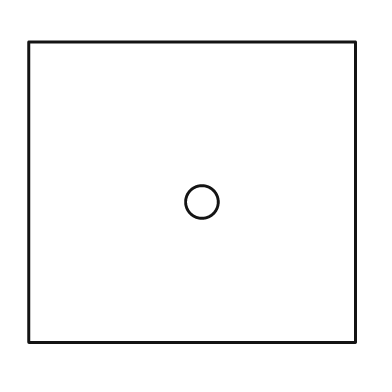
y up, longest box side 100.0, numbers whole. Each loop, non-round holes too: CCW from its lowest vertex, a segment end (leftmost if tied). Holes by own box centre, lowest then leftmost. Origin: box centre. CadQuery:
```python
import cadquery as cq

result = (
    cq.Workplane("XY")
    .moveTo(-50.0, -46.0)
    .lineTo(50.0, -46.0)
    .lineTo(50.0, 46.0)
    .lineTo(-50.0, 46.0)
    .close()
    .moveTo(3.0, -3.0)
    .circle(5.0)
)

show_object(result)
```